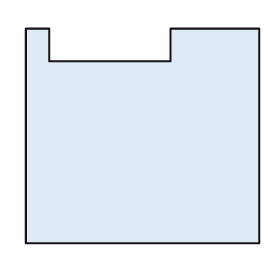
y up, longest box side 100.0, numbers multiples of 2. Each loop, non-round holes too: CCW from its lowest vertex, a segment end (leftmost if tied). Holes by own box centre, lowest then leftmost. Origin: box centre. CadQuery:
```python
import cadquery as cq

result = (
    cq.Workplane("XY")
    .moveTo(-50.0, -46.0)
    .lineTo(50.0, -46.0)
    .lineTo(50.0, 46.0)
    .lineTo(12.0, 46.0)
    .lineTo(12.0, 32.0)
    .lineTo(-40.0, 32.0)
    .lineTo(-40.0, 46.0)
    .lineTo(-50.0, 46.0)
    .close()
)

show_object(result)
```